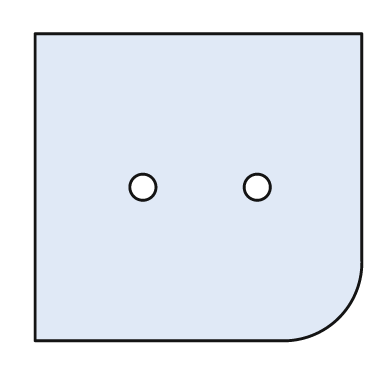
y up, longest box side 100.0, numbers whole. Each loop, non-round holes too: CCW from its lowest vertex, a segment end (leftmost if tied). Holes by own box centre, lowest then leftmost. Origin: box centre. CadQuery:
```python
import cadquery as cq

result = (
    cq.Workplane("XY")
    .moveTo(-50.0, -47.0)
    .lineTo(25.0, -47.0)
    .threePointArc((43.0, -40.0), (50.0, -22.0))
    .lineTo(50.0, 47.0)
    .lineTo(-50.0, 47.0)
    .close()
    .moveTo(-17.0, 0.0)
    .circle(4.0)
    .moveTo(18.0, 0.0)
    .circle(4.0)
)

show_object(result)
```